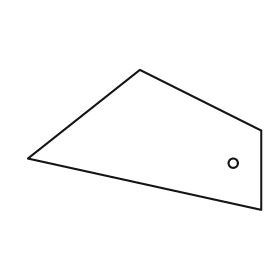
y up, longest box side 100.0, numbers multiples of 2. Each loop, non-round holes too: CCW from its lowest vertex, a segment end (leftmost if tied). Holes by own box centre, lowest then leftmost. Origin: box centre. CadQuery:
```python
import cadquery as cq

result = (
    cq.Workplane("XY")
    .moveTo(50.0, -30.0)
    .lineTo(50.0, 4.0)
    .lineTo(-2.0, 30.0)
    .lineTo(-50.0, -8.0)
    .close()
    .moveTo(38.0, -10.0)
    .circle(2.0)
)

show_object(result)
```